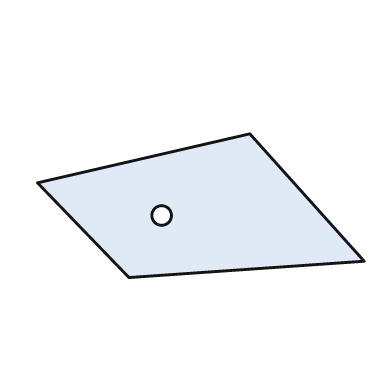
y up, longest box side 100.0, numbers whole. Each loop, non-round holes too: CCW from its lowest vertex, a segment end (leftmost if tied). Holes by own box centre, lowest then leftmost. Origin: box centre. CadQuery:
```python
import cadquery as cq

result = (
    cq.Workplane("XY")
    .moveTo(-22.0, -22.0)
    .lineTo(50.0, -17.0)
    .lineTo(15.0, 22.0)
    .lineTo(-50.0, 7.0)
    .close()
    .moveTo(-12.0, -3.0)
    .circle(3.0)
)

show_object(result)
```